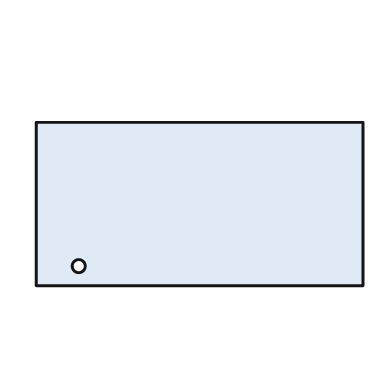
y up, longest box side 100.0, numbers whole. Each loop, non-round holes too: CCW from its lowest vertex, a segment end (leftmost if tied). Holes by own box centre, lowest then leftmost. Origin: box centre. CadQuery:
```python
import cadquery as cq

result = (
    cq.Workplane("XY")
    .moveTo(-50.0, -25.0)
    .lineTo(50.0, -25.0)
    .lineTo(50.0, 25.0)
    .lineTo(-50.0, 25.0)
    .close()
    .moveTo(-37.0, -19.0)
    .circle(2.0)
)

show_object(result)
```